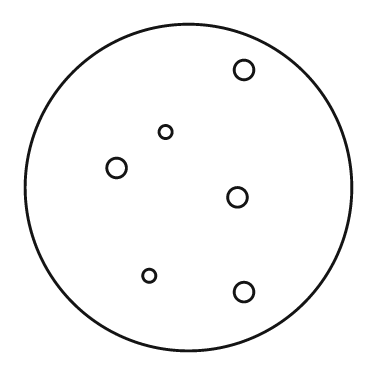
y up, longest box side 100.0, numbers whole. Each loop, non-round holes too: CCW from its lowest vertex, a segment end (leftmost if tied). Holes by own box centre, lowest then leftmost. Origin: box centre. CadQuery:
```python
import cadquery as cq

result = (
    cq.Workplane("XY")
    .moveTo(0.0, 0.0)
    .circle(50.0)
    .moveTo(17.0, -32.0)
    .circle(3.0)
    .moveTo(-12.0, -27.0)
    .circle(2.0)
    .moveTo(15.0, -3.0)
    .circle(3.0)
    .moveTo(-22.0, 6.0)
    .circle(3.0)
    .moveTo(-7.0, 17.0)
    .circle(2.0)
    .moveTo(17.0, 36.0)
    .circle(3.0)
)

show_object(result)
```